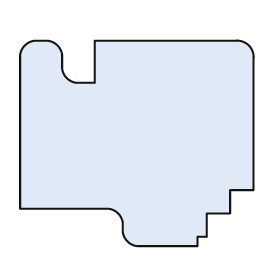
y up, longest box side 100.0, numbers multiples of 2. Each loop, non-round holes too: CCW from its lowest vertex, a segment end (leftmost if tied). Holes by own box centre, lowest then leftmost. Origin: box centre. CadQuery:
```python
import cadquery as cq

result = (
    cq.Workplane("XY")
    .moveTo(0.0, -44.0)
    .lineTo(26.0, -44.0)
    .lineTo(26.0, -40.0)
    .lineTo(30.0, -40.0)
    .lineTo(30.0, -30.0)
    .lineTo(40.0, -30.0)
    .lineTo(40.0, -20.0)
    .lineTo(50.0, -20.0)
    .lineTo(50.0, 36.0)
    .threePointArc((48.0, 42.0), (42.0, 44.0))
    .lineTo(-18.0, 44.0)
    .lineTo(-18.0, 26.0)
    .lineTo(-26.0, 26.0)
    .threePointArc((-30.0, 28.0), (-32.0, 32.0))
    .lineTo(-32.0, 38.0)
    .threePointArc((-34.0, 42.0), (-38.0, 44.0))
    .lineTo(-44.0, 44.0)
    .threePointArc((-48.0, 42.0), (-50.0, 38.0))
    .lineTo(-50.0, -28.0)
    .lineTo(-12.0, -28.0)
    .threePointArc((-8.0, -30.0), (-6.0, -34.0))
    .lineTo(-6.0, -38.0)
    .threePointArc((-4.0, -42.0), (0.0, -44.0))
    .close()
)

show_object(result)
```